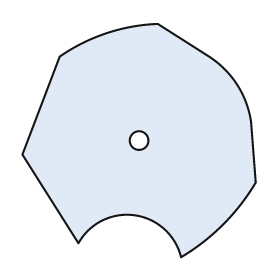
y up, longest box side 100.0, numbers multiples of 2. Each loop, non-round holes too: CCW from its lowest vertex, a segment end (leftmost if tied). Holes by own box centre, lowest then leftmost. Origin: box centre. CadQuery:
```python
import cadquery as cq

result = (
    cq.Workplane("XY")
    .moveTo(18.0, -50.0)
    .threePointArc((36.0, -36.0), (50.0, -18.0))
    .lineTo(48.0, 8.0)
    .threePointArc((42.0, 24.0), (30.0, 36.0))
    .lineTo(8.0, 50.0)
    .threePointArc((-14.0, 46.0), (-34.0, 36.0))
    .lineTo(-50.0, -6.0)
    .lineTo(-26.0, -44.0)
    .threePointArc((-2.0, -32.0), (18.0, -50.0))
    .close()
    .moveTo(0.0, 0.0)
    .circle(4.0)
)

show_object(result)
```